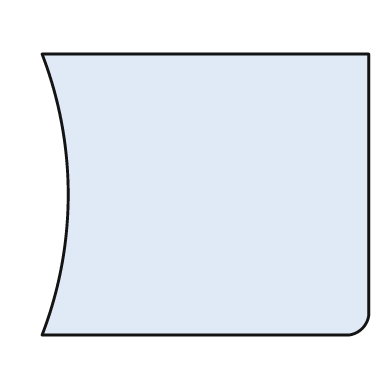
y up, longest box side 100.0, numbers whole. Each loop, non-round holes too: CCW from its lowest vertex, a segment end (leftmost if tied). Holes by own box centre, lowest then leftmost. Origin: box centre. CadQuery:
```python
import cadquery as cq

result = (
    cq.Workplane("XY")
    .moveTo(-50.0, -43.0)
    .lineTo(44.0, -43.0)
    .threePointArc((48.0, -41.0), (50.0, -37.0))
    .lineTo(50.0, 43.0)
    .lineTo(-50.0, 43.0)
    .threePointArc((-42.0, 0.0), (-50.0, -43.0))
    .close()
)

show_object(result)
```